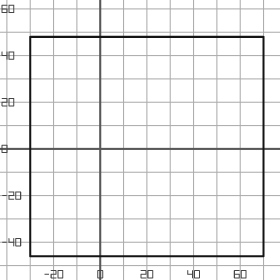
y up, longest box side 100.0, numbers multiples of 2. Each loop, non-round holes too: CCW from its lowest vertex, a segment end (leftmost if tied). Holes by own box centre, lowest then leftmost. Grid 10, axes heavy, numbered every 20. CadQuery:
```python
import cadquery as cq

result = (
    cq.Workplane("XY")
    .moveTo(-30.0, -46.0)
    .lineTo(70.0, -46.0)
    .lineTo(70.0, 48.0)
    .lineTo(-30.0, 48.0)
    .close()
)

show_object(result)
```